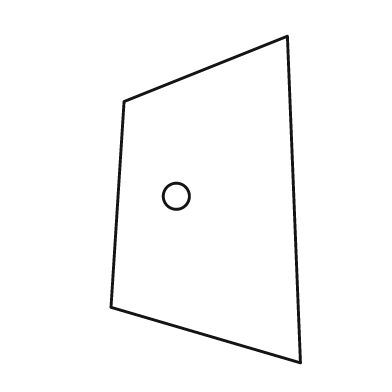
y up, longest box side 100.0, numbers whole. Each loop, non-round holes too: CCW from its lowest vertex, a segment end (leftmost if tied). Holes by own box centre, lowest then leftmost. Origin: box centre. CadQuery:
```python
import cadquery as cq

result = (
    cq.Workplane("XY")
    .moveTo(29.0, -50.0)
    .lineTo(25.0, 50.0)
    .lineTo(-25.0, 30.0)
    .lineTo(-29.0, -33.0)
    .close()
    .moveTo(-9.0, 1.0)
    .circle(4.0)
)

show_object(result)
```